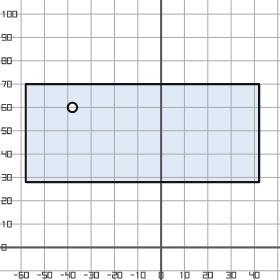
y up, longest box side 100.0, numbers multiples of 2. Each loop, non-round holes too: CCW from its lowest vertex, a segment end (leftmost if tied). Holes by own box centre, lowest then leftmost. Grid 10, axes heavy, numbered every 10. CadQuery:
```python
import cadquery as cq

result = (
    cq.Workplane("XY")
    .moveTo(-58.0, 28.0)
    .lineTo(42.0, 28.0)
    .lineTo(42.0, 70.0)
    .lineTo(-58.0, 70.0)
    .close()
    .moveTo(-38.0, 60.0)
    .circle(2.0)
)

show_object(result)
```